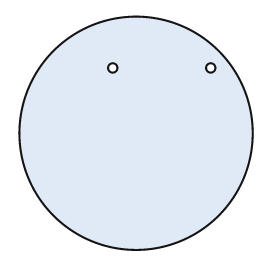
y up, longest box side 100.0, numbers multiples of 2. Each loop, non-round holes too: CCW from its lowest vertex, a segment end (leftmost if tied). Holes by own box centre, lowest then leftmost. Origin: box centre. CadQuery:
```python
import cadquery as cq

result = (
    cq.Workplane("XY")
    .moveTo(0.0, 0.0)
    .circle(50.0)
    .moveTo(-10.0, 28.0)
    .circle(2.0)
    .moveTo(32.0, 28.0)
    .circle(2.0)
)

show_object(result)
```